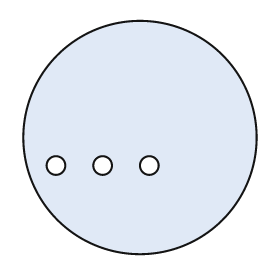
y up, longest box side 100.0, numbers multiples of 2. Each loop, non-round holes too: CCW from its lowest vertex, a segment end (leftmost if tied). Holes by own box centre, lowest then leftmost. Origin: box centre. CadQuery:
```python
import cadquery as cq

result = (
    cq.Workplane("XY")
    .moveTo(0.0, 0.0)
    .circle(50.0)
    .moveTo(-36.0, -12.0)
    .circle(4.0)
    .moveTo(-16.0, -12.0)
    .circle(4.0)
    .moveTo(4.0, -12.0)
    .circle(4.0)
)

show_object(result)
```